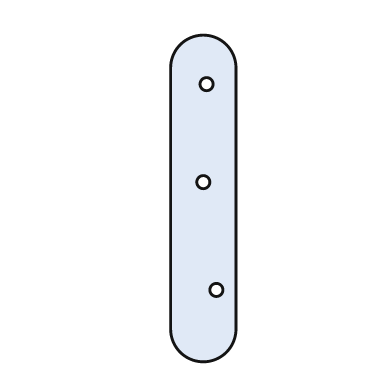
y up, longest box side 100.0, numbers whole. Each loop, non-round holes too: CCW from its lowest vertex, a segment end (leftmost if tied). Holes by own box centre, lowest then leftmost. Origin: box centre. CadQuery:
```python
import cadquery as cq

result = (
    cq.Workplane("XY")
    .moveTo(-10.0, -40.0)
    .threePointArc((0.0, -50.0), (10.0, -40.0))
    .lineTo(10.0, 40.0)
    .threePointArc((0.0, 50.0), (-10.0, 40.0))
    .close()
    .moveTo(4.0, -28.0)
    .circle(2.0)
    .moveTo(0.0, 5.0)
    .circle(2.0)
    .moveTo(1.0, 35.0)
    .circle(2.0)
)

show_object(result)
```